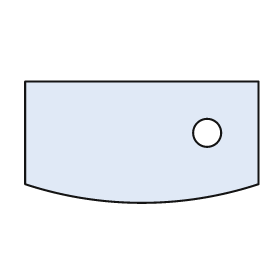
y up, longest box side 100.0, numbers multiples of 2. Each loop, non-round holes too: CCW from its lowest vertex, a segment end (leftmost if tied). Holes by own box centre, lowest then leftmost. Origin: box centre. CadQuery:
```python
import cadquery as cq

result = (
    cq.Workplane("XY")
    .moveTo(-50.0, -18.0)
    .threePointArc((0.0, -26.0), (50.0, -18.0))
    .lineTo(50.0, 26.0)
    .lineTo(-50.0, 26.0)
    .close()
    .moveTo(28.0, 4.0)
    .circle(6.0)
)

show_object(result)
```